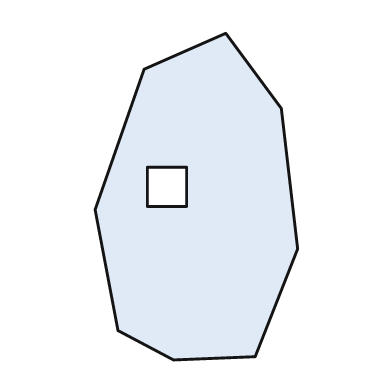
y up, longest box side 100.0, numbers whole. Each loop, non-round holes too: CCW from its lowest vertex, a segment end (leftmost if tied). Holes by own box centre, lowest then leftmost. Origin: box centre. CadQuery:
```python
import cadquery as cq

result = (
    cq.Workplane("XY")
    .moveTo(-7.0, -50.0)
    .lineTo(18.0, -49.0)
    .lineTo(31.0, -16.0)
    .lineTo(26.0, 27.0)
    .lineTo(9.0, 50.0)
    .lineTo(-16.0, 39.0)
    .lineTo(-31.0, -4.0)
    .lineTo(-24.0, -41.0)
    .close()
    .moveTo(-15.0, -3.0)
    .lineTo(-3.0, -3.0)
    .lineTo(-3.0, 9.0)
    .lineTo(-15.0, 9.0)
    .close()
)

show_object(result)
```